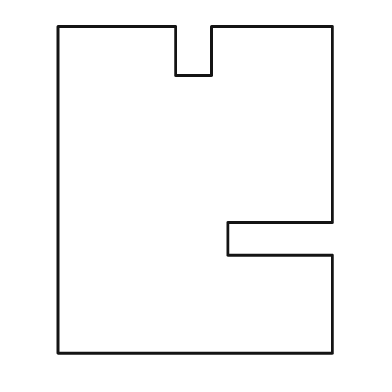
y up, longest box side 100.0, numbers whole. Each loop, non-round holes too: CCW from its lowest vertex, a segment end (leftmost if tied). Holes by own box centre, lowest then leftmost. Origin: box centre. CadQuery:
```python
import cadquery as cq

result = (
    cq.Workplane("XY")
    .moveTo(-42.0, -50.0)
    .lineTo(42.0, -50.0)
    .lineTo(42.0, -20.0)
    .lineTo(10.0, -20.0)
    .lineTo(10.0, -10.0)
    .lineTo(42.0, -10.0)
    .lineTo(42.0, 50.0)
    .lineTo(5.0, 50.0)
    .lineTo(5.0, 35.0)
    .lineTo(-6.0, 35.0)
    .lineTo(-6.0, 50.0)
    .lineTo(-42.0, 50.0)
    .close()
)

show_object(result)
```